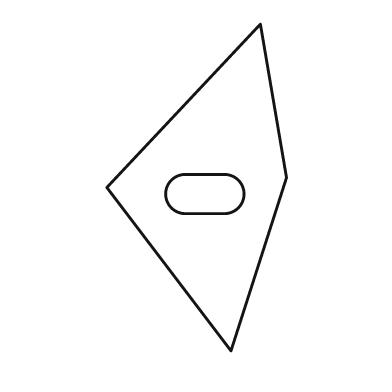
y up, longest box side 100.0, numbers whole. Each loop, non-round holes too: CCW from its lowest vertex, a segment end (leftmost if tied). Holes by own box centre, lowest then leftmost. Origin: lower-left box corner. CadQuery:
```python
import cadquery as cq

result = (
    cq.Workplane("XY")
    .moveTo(38.0, 0.0)
    .lineTo(55.0, 53.0)
    .lineTo(47.0, 100.0)
    .lineTo(0.0, 50.0)
    .close()
    .moveTo(24.0, 42.0)
    .lineTo(36.0, 42.0)
    .threePointArc((42.0, 48.0), (36.0, 54.0))
    .lineTo(24.0, 54.0)
    .threePointArc((18.0, 48.0), (24.0, 42.0))
    .close()
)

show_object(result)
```